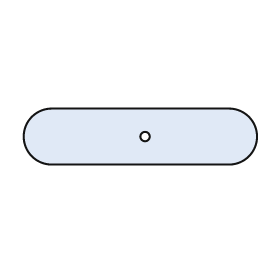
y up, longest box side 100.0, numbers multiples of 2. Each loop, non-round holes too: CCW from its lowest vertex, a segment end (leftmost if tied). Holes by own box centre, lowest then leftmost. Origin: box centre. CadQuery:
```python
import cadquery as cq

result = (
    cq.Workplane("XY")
    .moveTo(-38.0, -12.0)
    .lineTo(38.0, -12.0)
    .threePointArc((50.0, 0.0), (38.0, 12.0))
    .lineTo(-38.0, 12.0)
    .threePointArc((-50.0, 0.0), (-38.0, -12.0))
    .close()
    .moveTo(2.0, 0.0)
    .circle(2.0)
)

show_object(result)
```